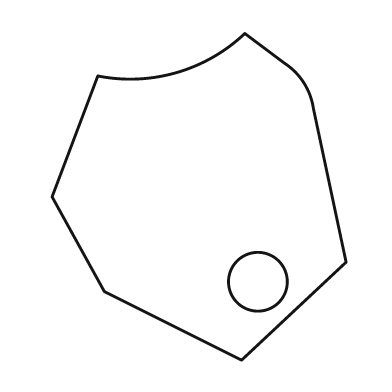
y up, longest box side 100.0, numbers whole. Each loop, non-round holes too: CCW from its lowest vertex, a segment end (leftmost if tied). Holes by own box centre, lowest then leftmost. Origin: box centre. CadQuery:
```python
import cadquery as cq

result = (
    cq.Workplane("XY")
    .moveTo(13.0, -50.0)
    .lineTo(45.0, -20.0)
    .lineTo(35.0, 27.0)
    .threePointArc((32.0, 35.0), (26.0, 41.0))
    .lineTo(14.0, 50.0)
    .threePointArc((-7.0, 38.0), (-31.0, 37.0))
    .lineTo(-45.0, 0.0)
    .lineTo(-29.0, -29.0)
    .close()
    .moveTo(18.0, -26.0)
    .circle(9.0)
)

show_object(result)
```